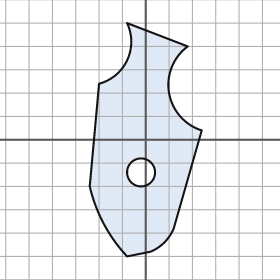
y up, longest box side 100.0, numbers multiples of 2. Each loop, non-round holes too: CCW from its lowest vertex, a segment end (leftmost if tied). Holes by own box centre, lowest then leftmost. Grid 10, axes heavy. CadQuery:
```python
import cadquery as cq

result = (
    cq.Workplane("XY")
    .moveTo(-8.0, -50.0)
    .lineTo(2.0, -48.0)
    .threePointArc((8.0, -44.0), (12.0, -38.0))
    .lineTo(24.0, 4.0)
    .threePointArc((10.0, 20.0), (18.0, 40.0))
    .lineTo(-8.0, 50.0)
    .threePointArc((-8.0, 34.0), (-20.0, 24.0))
    .lineTo(-24.0, -20.0)
    .threePointArc((-18.0, -36.0), (-8.0, -50.0))
    .close()
    .moveTo(-2.0, -14.0)
    .circle(6.0)
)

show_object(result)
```